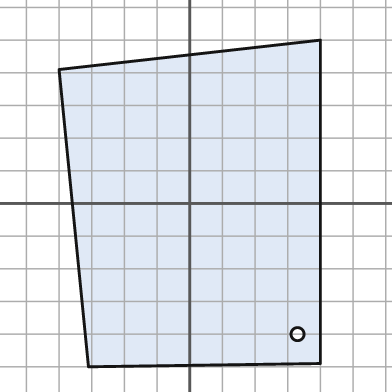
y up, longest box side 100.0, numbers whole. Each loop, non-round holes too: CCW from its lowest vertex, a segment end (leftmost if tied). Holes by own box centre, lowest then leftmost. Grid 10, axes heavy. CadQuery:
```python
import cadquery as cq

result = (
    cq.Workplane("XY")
    .moveTo(-31.0, -50.0)
    .lineTo(40.0, -49.0)
    .lineTo(40.0, 50.0)
    .lineTo(-40.0, 41.0)
    .close()
    .moveTo(33.0, -40.0)
    .circle(2.0)
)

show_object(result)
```